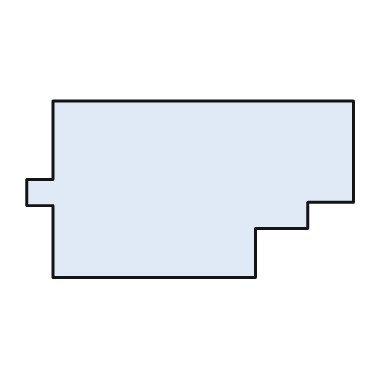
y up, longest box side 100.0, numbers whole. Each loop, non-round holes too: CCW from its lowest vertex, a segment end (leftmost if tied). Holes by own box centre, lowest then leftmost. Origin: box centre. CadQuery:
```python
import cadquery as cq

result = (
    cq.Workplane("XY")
    .moveTo(-42.0, -27.0)
    .lineTo(20.0, -27.0)
    .lineTo(20.0, -12.0)
    .lineTo(36.0, -12.0)
    .lineTo(36.0, -4.0)
    .lineTo(50.0, -4.0)
    .lineTo(50.0, 27.0)
    .lineTo(-42.0, 27.0)
    .lineTo(-42.0, 3.0)
    .lineTo(-50.0, 3.0)
    .lineTo(-50.0, -5.0)
    .lineTo(-42.0, -5.0)
    .close()
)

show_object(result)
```